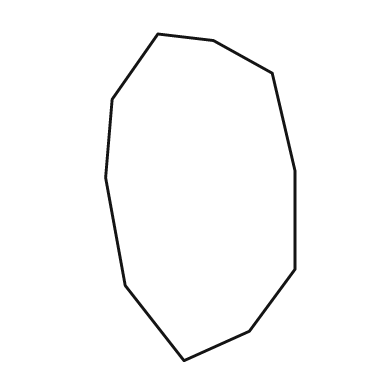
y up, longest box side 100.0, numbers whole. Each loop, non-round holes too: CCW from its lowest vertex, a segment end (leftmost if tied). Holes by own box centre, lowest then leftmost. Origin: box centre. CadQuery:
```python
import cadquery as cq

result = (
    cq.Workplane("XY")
    .moveTo(-5.0, -50.0)
    .lineTo(15.0, -41.0)
    .lineTo(29.0, -22.0)
    .lineTo(29.0, 8.0)
    .lineTo(22.0, 38.0)
    .lineTo(4.0, 48.0)
    .lineTo(-13.0, 50.0)
    .lineTo(-27.0, 30.0)
    .lineTo(-29.0, 6.0)
    .lineTo(-23.0, -27.0)
    .close()
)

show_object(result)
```